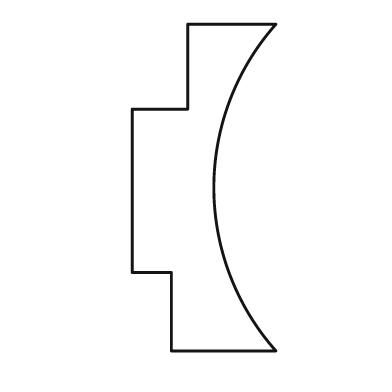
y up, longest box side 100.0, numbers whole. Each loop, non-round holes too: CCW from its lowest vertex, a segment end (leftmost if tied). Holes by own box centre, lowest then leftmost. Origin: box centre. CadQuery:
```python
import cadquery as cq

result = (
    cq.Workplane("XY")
    .moveTo(-10.0, -50.0)
    .lineTo(22.0, -50.0)
    .threePointArc((3.0, 0.0), (22.0, 50.0))
    .lineTo(-5.0, 50.0)
    .lineTo(-5.0, 24.0)
    .lineTo(-22.0, 24.0)
    .lineTo(-22.0, -26.0)
    .lineTo(-10.0, -26.0)
    .close()
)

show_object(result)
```